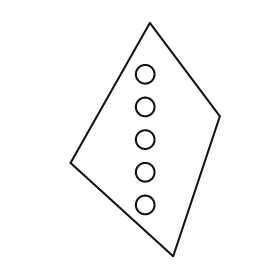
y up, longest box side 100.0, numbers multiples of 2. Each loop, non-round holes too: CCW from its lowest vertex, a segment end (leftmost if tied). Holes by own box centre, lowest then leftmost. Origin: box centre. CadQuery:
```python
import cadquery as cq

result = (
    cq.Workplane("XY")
    .moveTo(12.0, -50.0)
    .lineTo(32.0, 10.0)
    .lineTo(2.0, 50.0)
    .lineTo(-32.0, -10.0)
    .close()
    .moveTo(0.0, -28.0)
    .circle(4.0)
    .moveTo(0.0, -14.0)
    .circle(4.0)
    .moveTo(0.0, 0.0)
    .circle(4.0)
    .moveTo(0.0, 14.0)
    .circle(4.0)
    .moveTo(0.0, 28.0)
    .circle(4.0)
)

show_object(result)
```